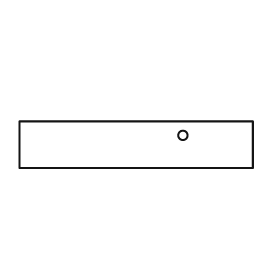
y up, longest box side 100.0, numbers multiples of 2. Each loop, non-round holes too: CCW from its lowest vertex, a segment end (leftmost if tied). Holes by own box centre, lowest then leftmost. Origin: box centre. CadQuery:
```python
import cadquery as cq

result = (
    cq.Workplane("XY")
    .moveTo(-50.0, -10.0)
    .lineTo(50.0, -10.0)
    .lineTo(50.0, 10.0)
    .lineTo(-50.0, 10.0)
    .close()
    .moveTo(20.0, 4.0)
    .circle(2.0)
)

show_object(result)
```